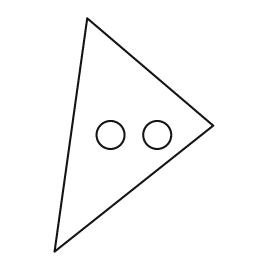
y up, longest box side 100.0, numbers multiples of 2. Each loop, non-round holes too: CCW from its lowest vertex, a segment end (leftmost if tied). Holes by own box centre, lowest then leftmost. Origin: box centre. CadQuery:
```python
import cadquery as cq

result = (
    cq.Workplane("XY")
    .moveTo(-34.0, -50.0)
    .lineTo(34.0, 4.0)
    .lineTo(-20.0, 50.0)
    .close()
    .moveTo(-10.0, 0.0)
    .circle(6.0)
    .moveTo(10.0, 0.0)
    .circle(6.0)
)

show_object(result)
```